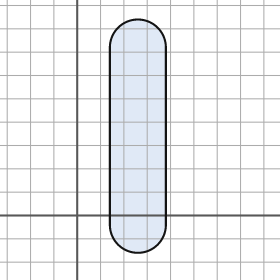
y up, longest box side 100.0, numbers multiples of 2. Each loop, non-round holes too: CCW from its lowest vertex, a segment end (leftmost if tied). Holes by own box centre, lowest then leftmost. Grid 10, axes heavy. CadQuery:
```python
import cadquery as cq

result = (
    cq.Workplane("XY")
    .moveTo(14.0, -4.0)
    .threePointArc((26.0, -16.0), (38.0, -4.0))
    .lineTo(38.0, 72.0)
    .threePointArc((26.0, 84.0), (14.0, 72.0))
    .close()
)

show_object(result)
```